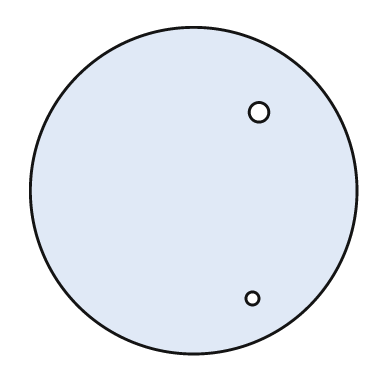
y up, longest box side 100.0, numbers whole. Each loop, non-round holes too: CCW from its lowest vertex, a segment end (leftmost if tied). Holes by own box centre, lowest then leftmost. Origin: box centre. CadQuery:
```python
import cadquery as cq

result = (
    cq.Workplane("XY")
    .moveTo(0.0, 0.0)
    .circle(50.0)
    .moveTo(18.0, -33.0)
    .circle(2.0)
    .moveTo(20.0, 24.0)
    .circle(3.0)
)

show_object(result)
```